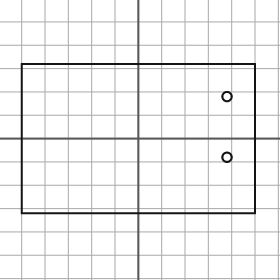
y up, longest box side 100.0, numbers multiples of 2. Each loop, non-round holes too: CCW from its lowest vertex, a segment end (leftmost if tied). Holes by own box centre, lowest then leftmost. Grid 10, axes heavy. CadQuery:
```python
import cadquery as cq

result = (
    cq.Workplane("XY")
    .moveTo(-50.0, -32.0)
    .lineTo(50.0, -32.0)
    .lineTo(50.0, 32.0)
    .lineTo(-50.0, 32.0)
    .close()
    .moveTo(38.0, -8.0)
    .circle(2.0)
    .moveTo(38.0, 18.0)
    .circle(2.0)
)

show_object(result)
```